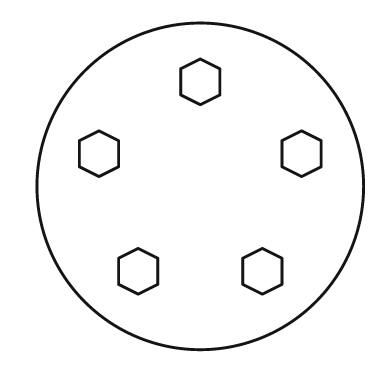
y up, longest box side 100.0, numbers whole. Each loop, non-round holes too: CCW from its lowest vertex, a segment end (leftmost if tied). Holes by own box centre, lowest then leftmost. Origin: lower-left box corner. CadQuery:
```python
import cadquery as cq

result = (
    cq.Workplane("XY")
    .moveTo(50.0, 50.0)
    .circle(50.0)
    .moveTo(31.0, 17.0)
    .lineTo(37.0, 20.0)
    .lineTo(37.0, 28.0)
    .lineTo(31.0, 31.0)
    .lineTo(25.0, 28.0)
    .lineTo(25.0, 20.0)
    .close()
    .moveTo(69.0, 17.0)
    .lineTo(75.0, 20.0)
    .lineTo(75.0, 28.0)
    .lineTo(69.0, 31.0)
    .lineTo(63.0, 28.0)
    .lineTo(63.0, 20.0)
    .close()
    .moveTo(19.0, 53.0)
    .lineTo(25.0, 56.0)
    .lineTo(25.0, 64.0)
    .lineTo(19.0, 67.0)
    .lineTo(13.0, 64.0)
    .lineTo(13.0, 56.0)
    .close()
    .moveTo(81.0, 53.0)
    .lineTo(87.0, 56.0)
    .lineTo(87.0, 64.0)
    .lineTo(81.0, 67.0)
    .lineTo(75.0, 64.0)
    .lineTo(75.0, 56.0)
    .close()
    .moveTo(50.0, 75.0)
    .lineTo(56.0, 78.0)
    .lineTo(56.0, 86.0)
    .lineTo(50.0, 89.0)
    .lineTo(44.0, 86.0)
    .lineTo(44.0, 78.0)
    .close()
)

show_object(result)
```